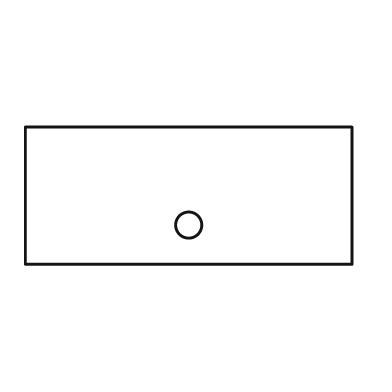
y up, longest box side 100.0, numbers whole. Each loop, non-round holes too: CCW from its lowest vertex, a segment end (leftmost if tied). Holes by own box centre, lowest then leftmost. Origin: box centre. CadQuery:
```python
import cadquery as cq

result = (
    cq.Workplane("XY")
    .moveTo(-50.0, -21.0)
    .lineTo(50.0, -21.0)
    .lineTo(50.0, 21.0)
    .lineTo(-50.0, 21.0)
    .close()
    .moveTo(0.0, -9.0)
    .circle(4.0)
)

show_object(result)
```